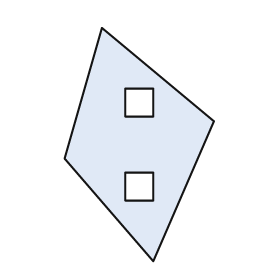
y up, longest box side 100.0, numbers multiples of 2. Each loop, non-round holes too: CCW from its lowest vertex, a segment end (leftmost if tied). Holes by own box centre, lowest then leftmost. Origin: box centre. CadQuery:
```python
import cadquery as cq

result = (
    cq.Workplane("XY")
    .moveTo(6.0, -50.0)
    .lineTo(32.0, 10.0)
    .lineTo(-16.0, 50.0)
    .lineTo(-32.0, -6.0)
    .close()
    .moveTo(-6.0, -24.0)
    .lineTo(6.0, -24.0)
    .lineTo(6.0, -12.0)
    .lineTo(-6.0, -12.0)
    .close()
    .moveTo(-6.0, 12.0)
    .lineTo(6.0, 12.0)
    .lineTo(6.0, 24.0)
    .lineTo(-6.0, 24.0)
    .close()
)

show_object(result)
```